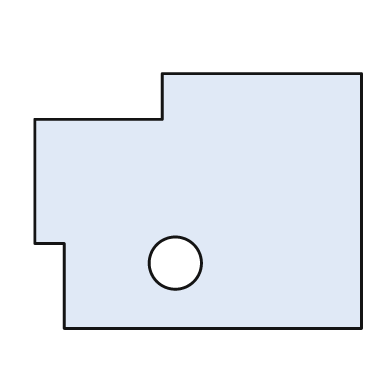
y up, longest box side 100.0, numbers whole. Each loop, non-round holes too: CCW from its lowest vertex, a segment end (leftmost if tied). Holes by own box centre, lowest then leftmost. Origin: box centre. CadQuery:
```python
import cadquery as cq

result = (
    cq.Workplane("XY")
    .moveTo(-41.0, -39.0)
    .lineTo(50.0, -39.0)
    .lineTo(50.0, 39.0)
    .lineTo(-11.0, 39.0)
    .lineTo(-11.0, 25.0)
    .lineTo(-50.0, 25.0)
    .lineTo(-50.0, -13.0)
    .lineTo(-41.0, -13.0)
    .close()
    .moveTo(-7.0, -19.0)
    .circle(8.0)
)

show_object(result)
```